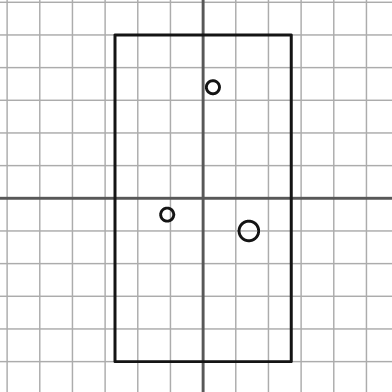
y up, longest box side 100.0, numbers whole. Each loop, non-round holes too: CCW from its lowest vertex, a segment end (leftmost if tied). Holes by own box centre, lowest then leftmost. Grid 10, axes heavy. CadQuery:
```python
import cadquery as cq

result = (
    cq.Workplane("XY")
    .moveTo(-27.0, -50.0)
    .lineTo(27.0, -50.0)
    .lineTo(27.0, 50.0)
    .lineTo(-27.0, 50.0)
    .close()
    .moveTo(14.0, -10.0)
    .circle(3.0)
    .moveTo(-11.0, -5.0)
    .circle(2.0)
    .moveTo(3.0, 34.0)
    .circle(2.0)
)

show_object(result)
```